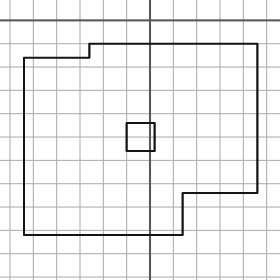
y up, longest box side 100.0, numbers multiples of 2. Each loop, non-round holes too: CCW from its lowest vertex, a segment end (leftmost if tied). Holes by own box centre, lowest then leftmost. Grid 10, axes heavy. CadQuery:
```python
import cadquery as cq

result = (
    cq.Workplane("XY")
    .moveTo(-54.0, -92.0)
    .lineTo(14.0, -92.0)
    .lineTo(14.0, -74.0)
    .lineTo(46.0, -74.0)
    .lineTo(46.0, -10.0)
    .lineTo(-26.0, -10.0)
    .lineTo(-26.0, -16.0)
    .lineTo(-54.0, -16.0)
    .close()
    .moveTo(-10.0, -56.0)
    .lineTo(2.0, -56.0)
    .lineTo(2.0, -44.0)
    .lineTo(-10.0, -44.0)
    .close()
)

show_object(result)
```